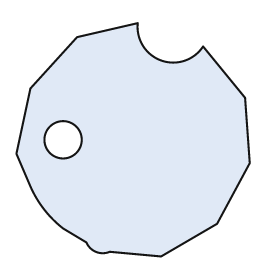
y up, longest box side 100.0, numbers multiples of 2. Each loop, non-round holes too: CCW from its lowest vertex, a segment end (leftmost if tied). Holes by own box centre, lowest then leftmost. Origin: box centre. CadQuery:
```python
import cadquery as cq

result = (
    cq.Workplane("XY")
    .moveTo(12.0, -50.0)
    .lineTo(36.0, -36.0)
    .lineTo(50.0, -10.0)
    .lineTo(48.0, 18.0)
    .lineTo(30.0, 40.0)
    .threePointArc((12.0, 34.0), (2.0, 50.0))
    .lineTo(-24.0, 44.0)
    .lineTo(-44.0, 22.0)
    .lineTo(-50.0, -6.0)
    .lineTo(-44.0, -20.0)
    .threePointArc((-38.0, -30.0), (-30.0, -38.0))
    .lineTo(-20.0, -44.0)
    .threePointArc((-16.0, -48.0), (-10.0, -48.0))
    .close()
    .moveTo(-30.0, 0.0)
    .circle(8.0)
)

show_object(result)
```